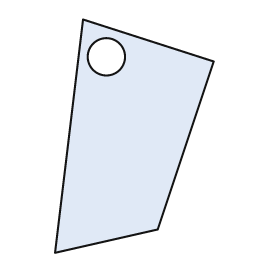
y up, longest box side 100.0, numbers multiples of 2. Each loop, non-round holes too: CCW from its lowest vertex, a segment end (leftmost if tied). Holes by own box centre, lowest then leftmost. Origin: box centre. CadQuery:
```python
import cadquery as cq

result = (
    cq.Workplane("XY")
    .moveTo(-34.0, -50.0)
    .lineTo(10.0, -40.0)
    .lineTo(34.0, 32.0)
    .lineTo(-22.0, 50.0)
    .close()
    .moveTo(-12.0, 34.0)
    .circle(8.0)
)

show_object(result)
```